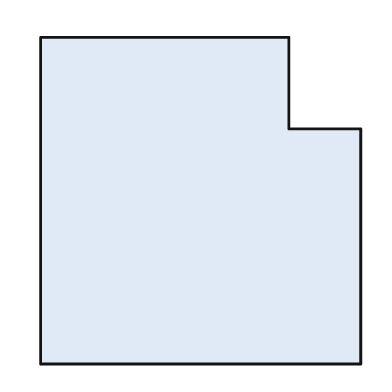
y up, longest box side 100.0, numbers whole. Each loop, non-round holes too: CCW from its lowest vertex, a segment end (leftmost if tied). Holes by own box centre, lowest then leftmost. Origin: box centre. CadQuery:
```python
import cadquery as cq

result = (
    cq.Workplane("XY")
    .moveTo(-49.0, -50.0)
    .lineTo(49.0, -50.0)
    .lineTo(49.0, 22.0)
    .lineTo(27.0, 22.0)
    .lineTo(27.0, 50.0)
    .lineTo(-49.0, 50.0)
    .close()
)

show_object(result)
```